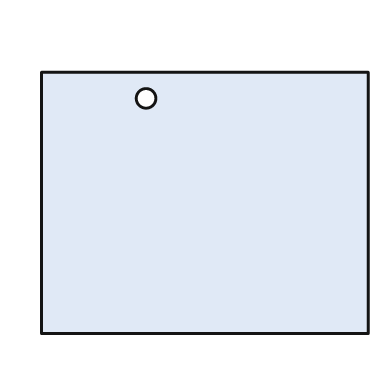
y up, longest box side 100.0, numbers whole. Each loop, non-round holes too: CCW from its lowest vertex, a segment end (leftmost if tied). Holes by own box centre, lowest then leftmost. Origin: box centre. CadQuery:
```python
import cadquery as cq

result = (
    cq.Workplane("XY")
    .moveTo(-50.0, -40.0)
    .lineTo(50.0, -40.0)
    .lineTo(50.0, 40.0)
    .lineTo(-50.0, 40.0)
    .close()
    .moveTo(-18.0, 32.0)
    .circle(3.0)
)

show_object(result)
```